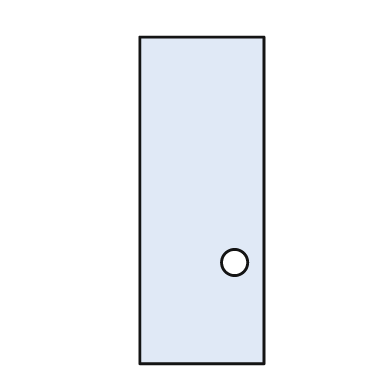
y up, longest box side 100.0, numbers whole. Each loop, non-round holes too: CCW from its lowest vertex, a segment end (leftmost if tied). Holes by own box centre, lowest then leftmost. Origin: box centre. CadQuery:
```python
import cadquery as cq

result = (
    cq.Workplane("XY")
    .moveTo(-19.0, -50.0)
    .lineTo(19.0, -50.0)
    .lineTo(19.0, 50.0)
    .lineTo(-19.0, 50.0)
    .close()
    .moveTo(10.0, -19.0)
    .circle(4.0)
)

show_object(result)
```